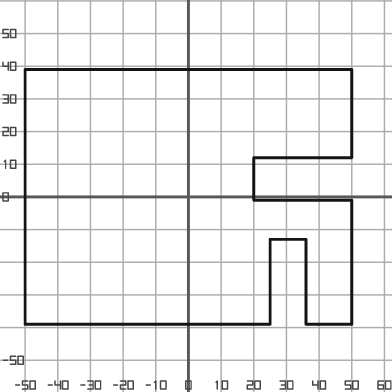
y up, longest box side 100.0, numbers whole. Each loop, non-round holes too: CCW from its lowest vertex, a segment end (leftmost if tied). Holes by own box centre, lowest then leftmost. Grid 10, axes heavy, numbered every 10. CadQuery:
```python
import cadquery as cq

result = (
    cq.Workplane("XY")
    .moveTo(-50.0, -39.0)
    .lineTo(25.0, -39.0)
    .lineTo(25.0, -13.0)
    .lineTo(36.0, -13.0)
    .lineTo(36.0, -39.0)
    .lineTo(50.0, -39.0)
    .lineTo(50.0, -1.0)
    .lineTo(20.0, -1.0)
    .lineTo(20.0, 12.0)
    .lineTo(50.0, 12.0)
    .lineTo(50.0, 39.0)
    .lineTo(-50.0, 39.0)
    .close()
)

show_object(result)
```